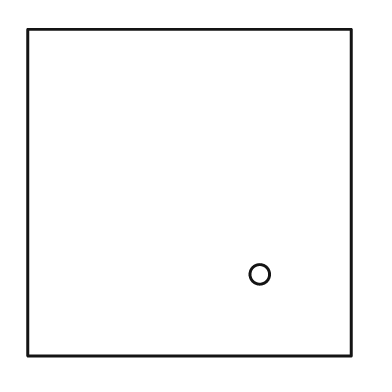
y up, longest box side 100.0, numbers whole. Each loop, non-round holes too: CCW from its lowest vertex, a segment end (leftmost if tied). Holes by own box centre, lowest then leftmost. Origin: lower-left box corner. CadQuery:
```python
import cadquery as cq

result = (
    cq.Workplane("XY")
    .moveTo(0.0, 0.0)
    .lineTo(99.0, 0.0)
    .lineTo(99.0, 100.0)
    .lineTo(0.0, 100.0)
    .close()
    .moveTo(71.0, 25.0)
    .circle(3.0)
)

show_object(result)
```